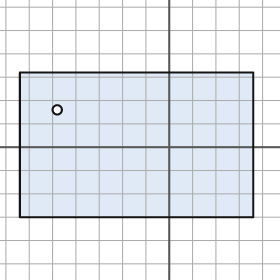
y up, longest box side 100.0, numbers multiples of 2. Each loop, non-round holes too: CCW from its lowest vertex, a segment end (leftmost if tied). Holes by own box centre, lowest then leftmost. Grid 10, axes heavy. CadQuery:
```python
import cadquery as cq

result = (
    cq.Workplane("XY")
    .moveTo(-64.0, -30.0)
    .lineTo(36.0, -30.0)
    .lineTo(36.0, 32.0)
    .lineTo(-64.0, 32.0)
    .close()
    .moveTo(-48.0, 16.0)
    .circle(2.0)
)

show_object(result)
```